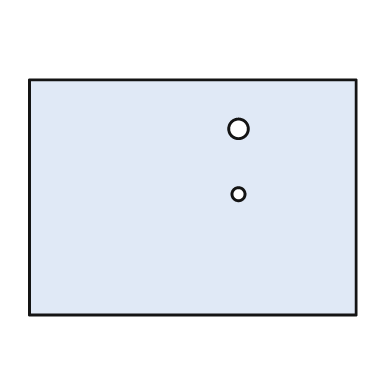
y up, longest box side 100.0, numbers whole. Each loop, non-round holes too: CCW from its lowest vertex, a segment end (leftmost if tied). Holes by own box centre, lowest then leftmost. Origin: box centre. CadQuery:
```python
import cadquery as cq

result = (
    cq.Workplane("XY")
    .moveTo(-50.0, -36.0)
    .lineTo(50.0, -36.0)
    .lineTo(50.0, 36.0)
    .lineTo(-50.0, 36.0)
    .close()
    .moveTo(14.0, 1.0)
    .circle(2.0)
    .moveTo(14.0, 21.0)
    .circle(3.0)
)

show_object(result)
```